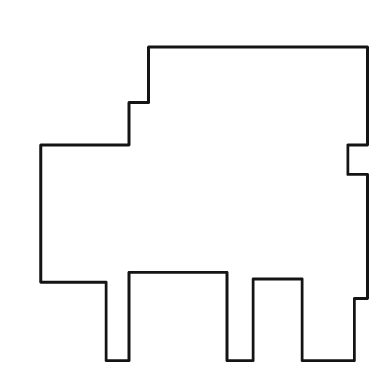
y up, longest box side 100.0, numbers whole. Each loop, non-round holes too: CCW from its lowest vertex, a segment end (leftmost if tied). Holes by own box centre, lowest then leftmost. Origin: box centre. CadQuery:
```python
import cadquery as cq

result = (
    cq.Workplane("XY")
    .moveTo(-30.0, -48.0)
    .lineTo(-23.0, -48.0)
    .lineTo(-23.0, -21.0)
    .lineTo(7.0, -21.0)
    .lineTo(7.0, -48.0)
    .lineTo(15.0, -48.0)
    .lineTo(15.0, -23.0)
    .lineTo(30.0, -23.0)
    .lineTo(30.0, -48.0)
    .lineTo(46.0, -48.0)
    .lineTo(46.0, -29.0)
    .lineTo(50.0, -29.0)
    .lineTo(50.0, 9.0)
    .lineTo(44.0, 9.0)
    .lineTo(44.0, 18.0)
    .lineTo(50.0, 18.0)
    .lineTo(50.0, 48.0)
    .lineTo(-17.0, 48.0)
    .lineTo(-17.0, 31.0)
    .lineTo(-23.0, 31.0)
    .lineTo(-23.0, 18.0)
    .lineTo(-50.0, 18.0)
    .lineTo(-50.0, -24.0)
    .lineTo(-30.0, -24.0)
    .close()
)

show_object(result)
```